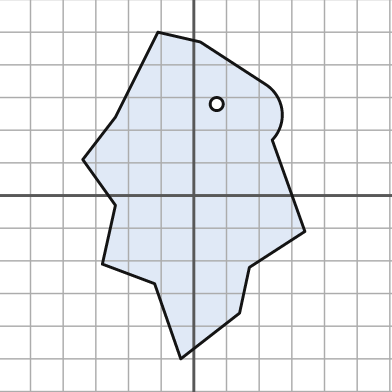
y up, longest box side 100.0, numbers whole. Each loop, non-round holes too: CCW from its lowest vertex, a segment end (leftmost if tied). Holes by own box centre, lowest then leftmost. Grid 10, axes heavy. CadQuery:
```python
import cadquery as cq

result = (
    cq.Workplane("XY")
    .moveTo(-4.0, -50.0)
    .lineTo(14.0, -36.0)
    .lineTo(17.0, -22.0)
    .lineTo(34.0, -11.0)
    .lineTo(24.0, 17.0)
    .threePointArc((27.0, 26.0), (22.0, 34.0))
    .lineTo(2.0, 47.0)
    .lineTo(-11.0, 50.0)
    .lineTo(-24.0, 24.0)
    .lineTo(-34.0, 11.0)
    .lineTo(-24.0, -3.0)
    .lineTo(-28.0, -21.0)
    .lineTo(-12.0, -27.0)
    .close()
    .moveTo(7.0, 28.0)
    .circle(2.0)
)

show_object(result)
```